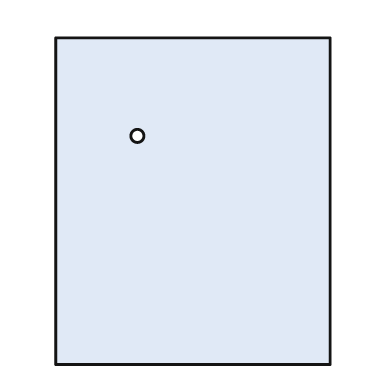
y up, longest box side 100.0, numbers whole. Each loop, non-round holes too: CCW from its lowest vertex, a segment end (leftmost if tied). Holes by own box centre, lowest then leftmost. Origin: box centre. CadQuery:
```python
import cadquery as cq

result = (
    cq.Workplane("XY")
    .moveTo(-42.0, -50.0)
    .lineTo(42.0, -50.0)
    .lineTo(42.0, 50.0)
    .lineTo(-42.0, 50.0)
    .close()
    .moveTo(-17.0, 20.0)
    .circle(2.0)
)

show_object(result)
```